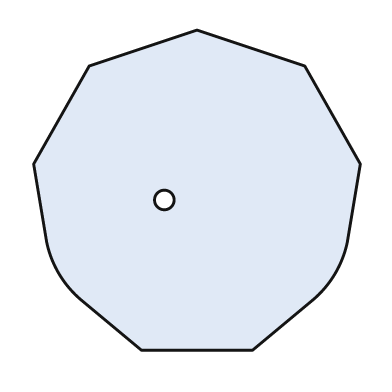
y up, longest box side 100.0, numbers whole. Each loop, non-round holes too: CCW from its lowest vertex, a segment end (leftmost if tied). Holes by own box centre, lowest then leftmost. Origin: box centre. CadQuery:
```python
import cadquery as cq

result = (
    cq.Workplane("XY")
    .moveTo(-17.0, -49.0)
    .lineTo(17.0, -49.0)
    .lineTo(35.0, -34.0)
    .threePointArc((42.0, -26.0), (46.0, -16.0))
    .lineTo(50.0, 8.0)
    .lineTo(33.0, 38.0)
    .lineTo(0.0, 49.0)
    .lineTo(-33.0, 38.0)
    .lineTo(-50.0, 8.0)
    .lineTo(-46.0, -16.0)
    .threePointArc((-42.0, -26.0), (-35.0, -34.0))
    .close()
    .moveTo(-10.0, -3.0)
    .circle(3.0)
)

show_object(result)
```